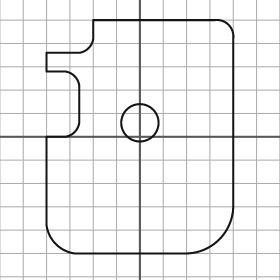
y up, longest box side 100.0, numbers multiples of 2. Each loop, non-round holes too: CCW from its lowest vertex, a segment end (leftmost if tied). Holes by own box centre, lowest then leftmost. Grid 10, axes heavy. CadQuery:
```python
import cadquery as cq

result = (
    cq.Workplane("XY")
    .moveTo(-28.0, -50.0)
    .lineTo(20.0, -50.0)
    .threePointArc((34.0, -44.0), (40.0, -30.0))
    .lineTo(40.0, 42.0)
    .threePointArc((38.0, 48.0), (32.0, 50.0))
    .lineTo(-20.0, 50.0)
    .lineTo(-20.0, 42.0)
    .threePointArc((-22.0, 38.0), (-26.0, 36.0))
    .lineTo(-40.0, 36.0)
    .lineTo(-40.0, 28.0)
    .lineTo(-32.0, 28.0)
    .threePointArc((-28.0, 26.0), (-26.0, 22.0))
    .lineTo(-26.0, 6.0)
    .threePointArc((-28.0, 2.0), (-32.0, 0.0))
    .lineTo(-40.0, 0.0)
    .lineTo(-40.0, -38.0)
    .threePointArc((-36.0, -46.0), (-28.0, -50.0))
    .close()
    .moveTo(0.0, 6.0)
    .circle(8.0)
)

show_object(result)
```